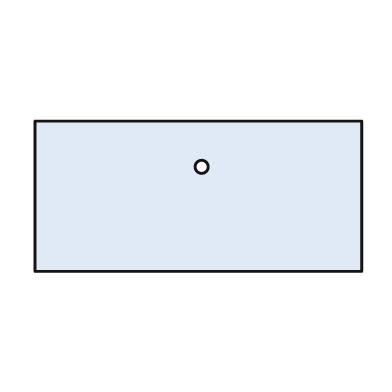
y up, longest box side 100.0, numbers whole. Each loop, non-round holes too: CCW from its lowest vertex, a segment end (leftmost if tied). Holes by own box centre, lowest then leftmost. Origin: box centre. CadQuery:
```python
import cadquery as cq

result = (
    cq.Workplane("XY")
    .moveTo(-50.0, -23.0)
    .lineTo(50.0, -23.0)
    .lineTo(50.0, 23.0)
    .lineTo(-50.0, 23.0)
    .close()
    .moveTo(1.0, 9.0)
    .circle(2.0)
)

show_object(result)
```